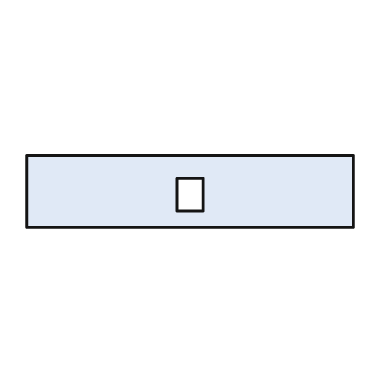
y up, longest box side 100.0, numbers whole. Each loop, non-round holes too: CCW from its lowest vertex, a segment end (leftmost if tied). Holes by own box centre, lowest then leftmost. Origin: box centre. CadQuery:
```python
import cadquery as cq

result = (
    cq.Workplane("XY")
    .moveTo(-50.0, -11.0)
    .lineTo(50.0, -11.0)
    .lineTo(50.0, 11.0)
    .lineTo(-50.0, 11.0)
    .close()
    .moveTo(-4.0, -6.0)
    .lineTo(4.0, -6.0)
    .lineTo(4.0, 4.0)
    .lineTo(-4.0, 4.0)
    .close()
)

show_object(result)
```